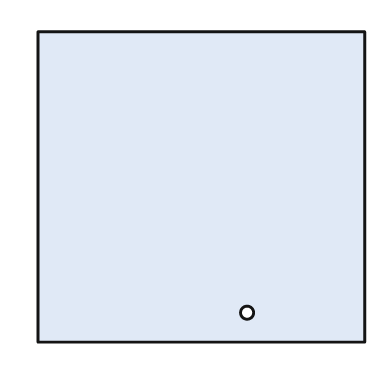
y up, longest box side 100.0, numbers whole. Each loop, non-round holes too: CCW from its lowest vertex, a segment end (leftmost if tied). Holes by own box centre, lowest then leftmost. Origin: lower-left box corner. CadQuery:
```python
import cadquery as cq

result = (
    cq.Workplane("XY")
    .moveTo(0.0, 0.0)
    .lineTo(100.0, 0.0)
    .lineTo(100.0, 95.0)
    .lineTo(0.0, 95.0)
    .close()
    .moveTo(64.0, 9.0)
    .circle(2.0)
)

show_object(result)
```